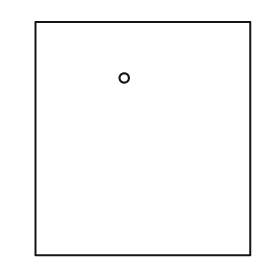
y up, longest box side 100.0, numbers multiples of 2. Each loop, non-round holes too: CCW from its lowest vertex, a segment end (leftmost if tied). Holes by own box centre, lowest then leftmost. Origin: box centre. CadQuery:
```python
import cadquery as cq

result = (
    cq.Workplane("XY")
    .moveTo(-46.0, -50.0)
    .lineTo(46.0, -50.0)
    .lineTo(46.0, 50.0)
    .lineTo(-46.0, 50.0)
    .close()
    .moveTo(-8.0, 26.0)
    .circle(2.0)
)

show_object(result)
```